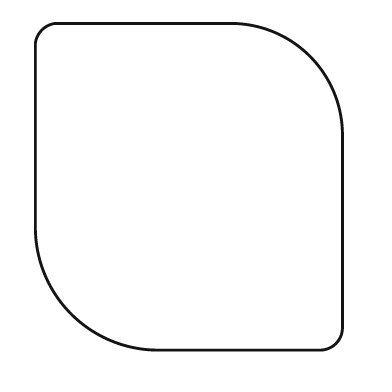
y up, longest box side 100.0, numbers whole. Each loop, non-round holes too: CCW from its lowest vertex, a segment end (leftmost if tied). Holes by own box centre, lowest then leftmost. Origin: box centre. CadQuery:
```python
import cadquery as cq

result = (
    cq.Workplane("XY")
    .moveTo(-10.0, -50.0)
    .lineTo(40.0, -50.0)
    .threePointArc((45.0, -48.0), (47.0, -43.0))
    .lineTo(47.0, 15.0)
    .threePointArc((37.0, 40.0), (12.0, 50.0))
    .lineTo(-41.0, 50.0)
    .threePointArc((-45.0, 48.0), (-47.0, 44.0))
    .lineTo(-47.0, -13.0)
    .threePointArc((-36.0, -39.0), (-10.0, -50.0))
    .close()
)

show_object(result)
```